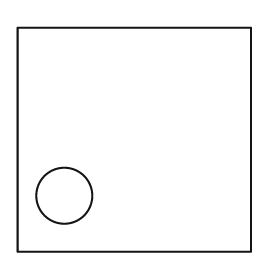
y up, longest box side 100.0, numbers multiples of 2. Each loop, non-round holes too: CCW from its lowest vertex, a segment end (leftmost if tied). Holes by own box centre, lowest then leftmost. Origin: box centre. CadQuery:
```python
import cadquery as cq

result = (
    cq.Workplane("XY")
    .moveTo(-50.0, -48.0)
    .lineTo(50.0, -48.0)
    .lineTo(50.0, 48.0)
    .lineTo(-50.0, 48.0)
    .close()
    .moveTo(-30.0, -24.0)
    .circle(12.0)
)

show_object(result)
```